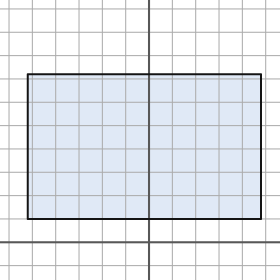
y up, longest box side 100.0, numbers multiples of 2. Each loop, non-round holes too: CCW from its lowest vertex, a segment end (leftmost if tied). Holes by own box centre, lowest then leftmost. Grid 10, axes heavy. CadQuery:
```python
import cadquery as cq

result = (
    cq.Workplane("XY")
    .moveTo(-52.0, 10.0)
    .lineTo(48.0, 10.0)
    .lineTo(48.0, 72.0)
    .lineTo(-52.0, 72.0)
    .close()
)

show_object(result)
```